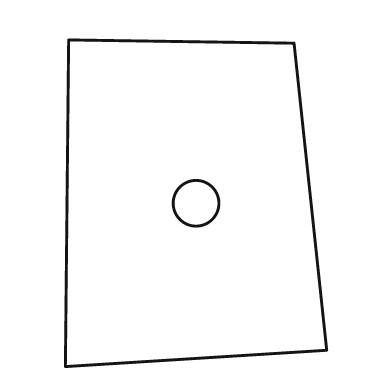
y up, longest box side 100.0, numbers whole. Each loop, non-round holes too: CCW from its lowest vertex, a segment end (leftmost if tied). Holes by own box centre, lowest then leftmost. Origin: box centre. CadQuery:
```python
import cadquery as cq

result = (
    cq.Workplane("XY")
    .moveTo(-40.0, -50.0)
    .lineTo(40.0, -45.0)
    .lineTo(30.0, 49.0)
    .lineTo(-39.0, 50.0)
    .close()
    .moveTo(0.0, 0.0)
    .circle(7.0)
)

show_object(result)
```